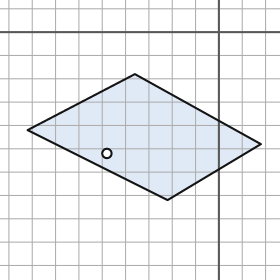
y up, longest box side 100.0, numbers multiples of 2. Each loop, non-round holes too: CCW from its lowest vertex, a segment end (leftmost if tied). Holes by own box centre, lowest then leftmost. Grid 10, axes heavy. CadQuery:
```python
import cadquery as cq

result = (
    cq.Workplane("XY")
    .moveTo(-22.0, -72.0)
    .lineTo(18.0, -48.0)
    .lineTo(-36.0, -18.0)
    .lineTo(-82.0, -42.0)
    .close()
    .moveTo(-48.0, -52.0)
    .circle(2.0)
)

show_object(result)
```